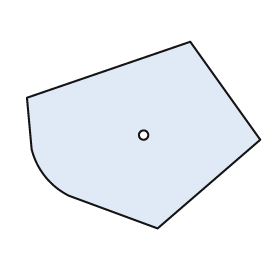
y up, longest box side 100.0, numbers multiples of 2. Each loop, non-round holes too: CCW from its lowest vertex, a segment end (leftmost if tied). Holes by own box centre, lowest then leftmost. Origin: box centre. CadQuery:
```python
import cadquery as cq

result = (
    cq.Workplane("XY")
    .moveTo(6.0, -40.0)
    .lineTo(50.0, -2.0)
    .lineTo(20.0, 40.0)
    .lineTo(-50.0, 16.0)
    .lineTo(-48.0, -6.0)
    .threePointArc((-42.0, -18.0), (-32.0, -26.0))
    .close()
    .moveTo(0.0, 0.0)
    .circle(2.0)
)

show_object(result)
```